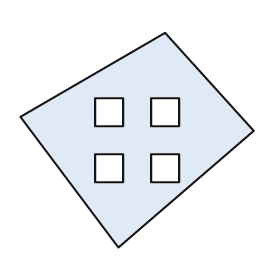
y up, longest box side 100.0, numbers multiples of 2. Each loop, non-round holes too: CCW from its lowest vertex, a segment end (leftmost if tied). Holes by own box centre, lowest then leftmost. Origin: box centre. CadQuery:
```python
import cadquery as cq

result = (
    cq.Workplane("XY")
    .moveTo(-8.0, -46.0)
    .lineTo(50.0, 4.0)
    .lineTo(12.0, 46.0)
    .lineTo(-50.0, 10.0)
    .close()
    .moveTo(-18.0, -18.0)
    .lineTo(-6.0, -18.0)
    .lineTo(-6.0, -6.0)
    .lineTo(-18.0, -6.0)
    .close()
    .moveTo(6.0, -18.0)
    .lineTo(18.0, -18.0)
    .lineTo(18.0, -6.0)
    .lineTo(6.0, -6.0)
    .close()
    .moveTo(-18.0, 6.0)
    .lineTo(-6.0, 6.0)
    .lineTo(-6.0, 18.0)
    .lineTo(-18.0, 18.0)
    .close()
    .moveTo(6.0, 6.0)
    .lineTo(18.0, 6.0)
    .lineTo(18.0, 18.0)
    .lineTo(6.0, 18.0)
    .close()
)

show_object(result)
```